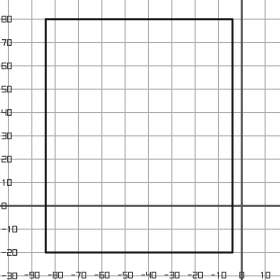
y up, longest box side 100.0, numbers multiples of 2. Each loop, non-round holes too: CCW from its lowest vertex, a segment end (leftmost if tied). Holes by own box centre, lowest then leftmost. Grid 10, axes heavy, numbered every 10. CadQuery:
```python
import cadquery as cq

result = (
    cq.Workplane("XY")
    .moveTo(-84.0, -20.0)
    .lineTo(-4.0, -20.0)
    .lineTo(-4.0, 80.0)
    .lineTo(-84.0, 80.0)
    .close()
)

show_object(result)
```